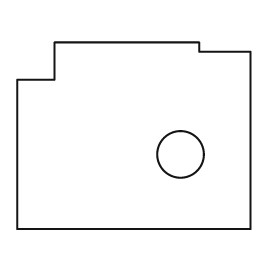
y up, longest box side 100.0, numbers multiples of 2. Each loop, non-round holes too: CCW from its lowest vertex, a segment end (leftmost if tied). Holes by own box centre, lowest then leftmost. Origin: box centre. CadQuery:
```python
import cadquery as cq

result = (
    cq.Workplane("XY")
    .moveTo(-50.0, -40.0)
    .lineTo(50.0, -40.0)
    .lineTo(50.0, 36.0)
    .lineTo(28.0, 36.0)
    .lineTo(28.0, 40.0)
    .lineTo(-34.0, 40.0)
    .lineTo(-34.0, 24.0)
    .lineTo(-50.0, 24.0)
    .close()
    .moveTo(20.0, -8.0)
    .circle(10.0)
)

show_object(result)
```